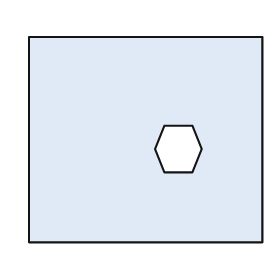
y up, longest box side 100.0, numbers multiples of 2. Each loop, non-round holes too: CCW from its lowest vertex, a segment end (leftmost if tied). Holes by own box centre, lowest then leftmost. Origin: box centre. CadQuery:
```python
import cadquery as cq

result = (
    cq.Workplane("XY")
    .moveTo(-50.0, -44.0)
    .lineTo(50.0, -44.0)
    .lineTo(50.0, 44.0)
    .lineTo(-50.0, 44.0)
    .close()
    .moveTo(8.0, -14.0)
    .lineTo(20.0, -14.0)
    .lineTo(24.0, -4.0)
    .lineTo(20.0, 6.0)
    .lineTo(8.0, 6.0)
    .lineTo(4.0, -4.0)
    .close()
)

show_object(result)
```